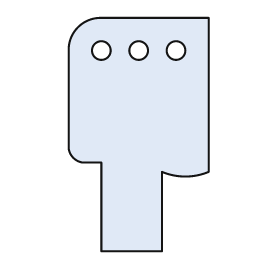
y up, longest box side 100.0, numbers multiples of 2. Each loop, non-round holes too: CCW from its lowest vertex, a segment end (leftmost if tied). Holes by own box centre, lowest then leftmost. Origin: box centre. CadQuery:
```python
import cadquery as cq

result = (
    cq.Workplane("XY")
    .moveTo(-16.0, -50.0)
    .lineTo(10.0, -50.0)
    .lineTo(10.0, -16.0)
    .threePointArc((20.0, -18.0), (30.0, -16.0))
    .lineTo(30.0, 50.0)
    .lineTo(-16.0, 50.0)
    .threePointArc((-26.0, 46.0), (-30.0, 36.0))
    .lineTo(-30.0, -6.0)
    .threePointArc((-28.0, -10.0), (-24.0, -12.0))
    .lineTo(-16.0, -12.0)
    .close()
    .moveTo(-16.0, 36.0)
    .circle(4.0)
    .moveTo(0.0, 36.0)
    .circle(4.0)
    .moveTo(16.0, 36.0)
    .circle(4.0)
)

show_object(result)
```